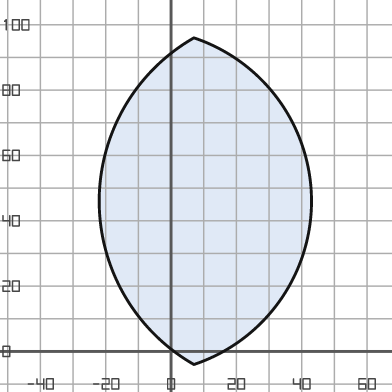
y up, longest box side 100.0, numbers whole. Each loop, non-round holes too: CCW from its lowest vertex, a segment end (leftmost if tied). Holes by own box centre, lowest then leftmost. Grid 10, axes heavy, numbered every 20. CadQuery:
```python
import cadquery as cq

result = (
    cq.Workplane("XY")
    .moveTo(7.0, -4.0)
    .threePointArc((43.0, 46.0), (7.0, 96.0))
    .threePointArc((-22.0, 46.0), (7.0, -4.0))
    .close()
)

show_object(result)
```